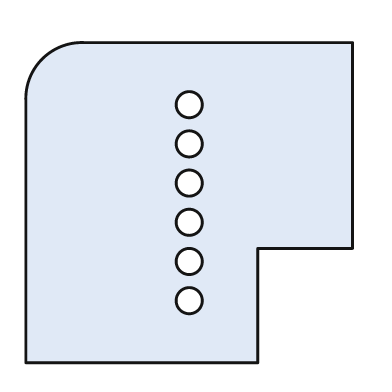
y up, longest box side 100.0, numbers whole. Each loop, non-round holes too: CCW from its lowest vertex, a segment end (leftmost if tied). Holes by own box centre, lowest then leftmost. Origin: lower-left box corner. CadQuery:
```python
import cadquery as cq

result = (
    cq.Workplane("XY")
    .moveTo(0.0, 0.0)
    .lineTo(71.0, 0.0)
    .lineTo(71.0, 35.0)
    .lineTo(100.0, 35.0)
    .lineTo(100.0, 98.0)
    .lineTo(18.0, 98.0)
    .threePointArc((5.0, 93.0), (0.0, 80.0))
    .close()
    .moveTo(50.0, 19.0)
    .circle(4.0)
    .moveTo(50.0, 31.0)
    .circle(4.0)
    .moveTo(50.0, 43.0)
    .circle(4.0)
    .moveTo(50.0, 55.0)
    .circle(4.0)
    .moveTo(50.0, 67.0)
    .circle(4.0)
    .moveTo(50.0, 79.0)
    .circle(4.0)
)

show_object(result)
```